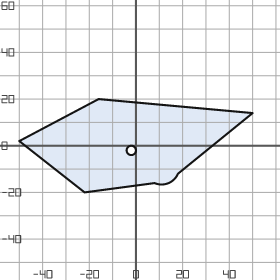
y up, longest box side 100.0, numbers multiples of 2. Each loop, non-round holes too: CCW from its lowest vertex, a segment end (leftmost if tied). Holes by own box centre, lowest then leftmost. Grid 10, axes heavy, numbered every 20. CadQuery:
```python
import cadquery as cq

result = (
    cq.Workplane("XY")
    .moveTo(-22.0, -20.0)
    .lineTo(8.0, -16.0)
    .threePointArc((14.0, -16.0), (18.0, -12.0))
    .lineTo(50.0, 14.0)
    .lineTo(-16.0, 20.0)
    .lineTo(-50.0, 2.0)
    .close()
    .moveTo(-2.0, -2.0)
    .circle(2.0)
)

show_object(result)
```